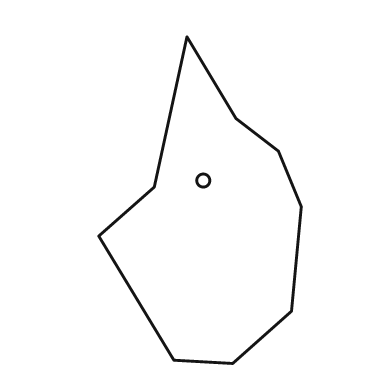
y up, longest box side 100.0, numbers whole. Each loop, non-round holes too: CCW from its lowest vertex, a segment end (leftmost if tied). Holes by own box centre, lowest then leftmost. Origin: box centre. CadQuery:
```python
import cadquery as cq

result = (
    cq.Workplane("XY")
    .moveTo(10.0, -50.0)
    .lineTo(28.0, -34.0)
    .lineTo(31.0, -2.0)
    .lineTo(24.0, 15.0)
    .lineTo(11.0, 25.0)
    .lineTo(-4.0, 50.0)
    .lineTo(-14.0, 4.0)
    .lineTo(-31.0, -11.0)
    .lineTo(-8.0, -49.0)
    .close()
    .moveTo(1.0, 6.0)
    .circle(2.0)
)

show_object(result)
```